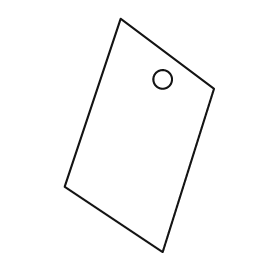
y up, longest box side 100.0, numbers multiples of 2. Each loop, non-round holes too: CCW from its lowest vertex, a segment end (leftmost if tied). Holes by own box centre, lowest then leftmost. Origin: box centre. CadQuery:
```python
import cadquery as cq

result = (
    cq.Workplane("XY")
    .moveTo(10.0, -50.0)
    .lineTo(32.0, 20.0)
    .lineTo(-8.0, 50.0)
    .lineTo(-32.0, -22.0)
    .close()
    .moveTo(10.0, 24.0)
    .circle(4.0)
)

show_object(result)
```